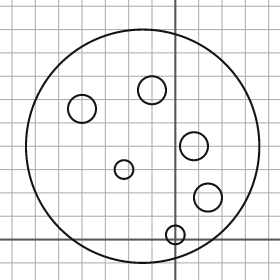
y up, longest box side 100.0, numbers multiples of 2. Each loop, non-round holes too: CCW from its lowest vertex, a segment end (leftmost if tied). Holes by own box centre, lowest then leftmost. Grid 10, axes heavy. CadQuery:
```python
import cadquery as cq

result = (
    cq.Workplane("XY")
    .moveTo(-14.0, 40.0)
    .circle(50.0)
    .moveTo(0.0, 2.0)
    .circle(4.0)
    .moveTo(14.0, 18.0)
    .circle(6.0)
    .moveTo(-22.0, 30.0)
    .circle(4.0)
    .moveTo(8.0, 40.0)
    .circle(6.0)
    .moveTo(-40.0, 56.0)
    .circle(6.0)
    .moveTo(-10.0, 64.0)
    .circle(6.0)
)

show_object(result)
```